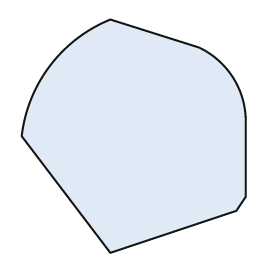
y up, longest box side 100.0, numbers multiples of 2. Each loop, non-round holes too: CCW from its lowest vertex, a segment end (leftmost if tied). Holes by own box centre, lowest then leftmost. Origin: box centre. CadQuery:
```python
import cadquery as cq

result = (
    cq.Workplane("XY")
    .moveTo(-10.0, -50.0)
    .lineTo(44.0, -32.0)
    .lineTo(48.0, -26.0)
    .lineTo(48.0, 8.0)
    .threePointArc((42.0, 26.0), (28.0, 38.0))
    .lineTo(-10.0, 50.0)
    .threePointArc((-36.0, 30.0), (-48.0, 0.0))
    .close()
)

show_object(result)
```